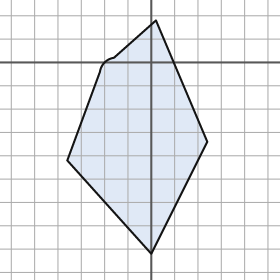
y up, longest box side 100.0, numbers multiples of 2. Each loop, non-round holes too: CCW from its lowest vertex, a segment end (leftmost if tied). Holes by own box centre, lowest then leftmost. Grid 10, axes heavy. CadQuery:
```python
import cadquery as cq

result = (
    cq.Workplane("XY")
    .moveTo(0.0, -82.0)
    .lineTo(24.0, -34.0)
    .lineTo(2.0, 18.0)
    .lineTo(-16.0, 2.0)
    .threePointArc((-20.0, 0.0), (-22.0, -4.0))
    .lineTo(-36.0, -42.0)
    .close()
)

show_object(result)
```